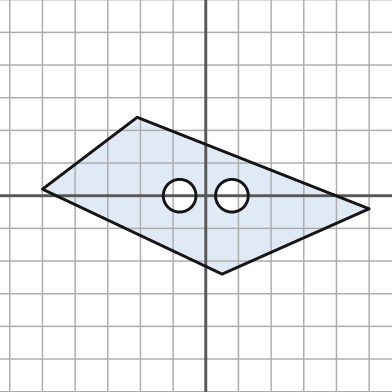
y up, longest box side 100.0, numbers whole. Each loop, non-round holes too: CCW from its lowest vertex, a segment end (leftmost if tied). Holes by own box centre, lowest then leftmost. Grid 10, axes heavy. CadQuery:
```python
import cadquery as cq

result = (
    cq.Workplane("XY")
    .moveTo(5.0, -24.0)
    .lineTo(50.0, -4.0)
    .lineTo(-21.0, 24.0)
    .lineTo(-50.0, 2.0)
    .close()
    .moveTo(-8.0, 0.0)
    .circle(5.0)
    .moveTo(8.0, 0.0)
    .circle(5.0)
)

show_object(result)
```